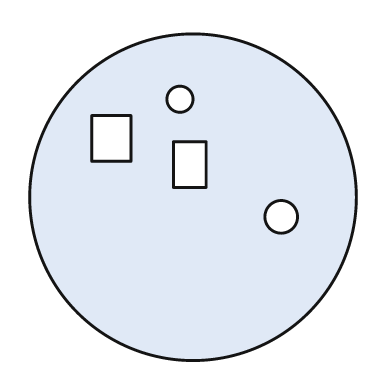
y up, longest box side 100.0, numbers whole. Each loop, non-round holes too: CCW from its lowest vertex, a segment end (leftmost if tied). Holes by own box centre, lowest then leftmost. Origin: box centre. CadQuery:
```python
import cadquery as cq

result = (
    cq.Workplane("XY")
    .moveTo(0.0, 0.0)
    .circle(50.0)
    .moveTo(27.0, -6.0)
    .circle(5.0)
    .moveTo(-6.0, 3.0)
    .lineTo(4.0, 3.0)
    .lineTo(4.0, 17.0)
    .lineTo(-6.0, 17.0)
    .close()
    .moveTo(-31.0, 11.0)
    .lineTo(-19.0, 11.0)
    .lineTo(-19.0, 25.0)
    .lineTo(-31.0, 25.0)
    .close()
    .moveTo(-4.0, 30.0)
    .circle(4.0)
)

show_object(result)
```